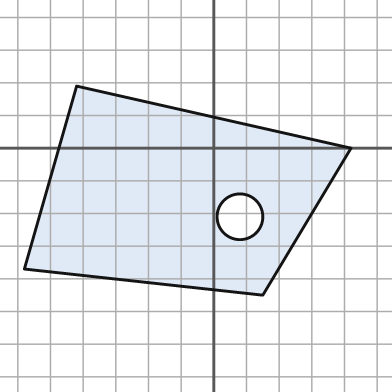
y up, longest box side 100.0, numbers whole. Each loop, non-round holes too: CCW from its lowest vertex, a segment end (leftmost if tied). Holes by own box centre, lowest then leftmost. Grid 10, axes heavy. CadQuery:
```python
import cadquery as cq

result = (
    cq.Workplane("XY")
    .moveTo(15.0, -45.0)
    .lineTo(42.0, 0.0)
    .lineTo(-42.0, 19.0)
    .lineTo(-58.0, -37.0)
    .close()
    .moveTo(8.0, -21.0)
    .circle(7.0)
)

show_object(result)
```